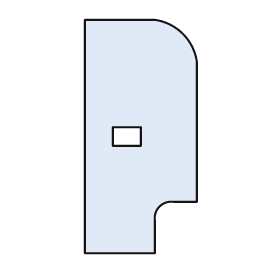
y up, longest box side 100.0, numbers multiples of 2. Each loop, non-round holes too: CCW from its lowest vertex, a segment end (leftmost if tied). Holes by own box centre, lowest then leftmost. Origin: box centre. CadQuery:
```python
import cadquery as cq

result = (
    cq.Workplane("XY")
    .moveTo(-24.0, -50.0)
    .lineTo(6.0, -50.0)
    .lineTo(6.0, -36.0)
    .threePointArc((8.0, -30.0), (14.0, -28.0))
    .lineTo(24.0, -28.0)
    .lineTo(24.0, 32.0)
    .threePointArc((18.0, 44.0), (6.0, 50.0))
    .lineTo(-24.0, 50.0)
    .close()
    .moveTo(-12.0, -4.0)
    .lineTo(0.0, -4.0)
    .lineTo(0.0, 4.0)
    .lineTo(-12.0, 4.0)
    .close()
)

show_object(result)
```